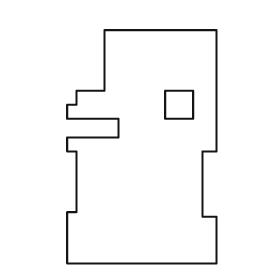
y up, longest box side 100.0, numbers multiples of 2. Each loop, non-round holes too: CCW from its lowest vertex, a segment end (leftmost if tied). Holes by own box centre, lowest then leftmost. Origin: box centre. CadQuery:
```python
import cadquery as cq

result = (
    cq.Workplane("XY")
    .moveTo(-32.0, -50.0)
    .lineTo(32.0, -50.0)
    .lineTo(32.0, -30.0)
    .lineTo(26.0, -30.0)
    .lineTo(26.0, -2.0)
    .lineTo(32.0, -2.0)
    .lineTo(32.0, 50.0)
    .lineTo(-16.0, 50.0)
    .lineTo(-16.0, 24.0)
    .lineTo(-28.0, 24.0)
    .lineTo(-28.0, 18.0)
    .lineTo(-32.0, 18.0)
    .lineTo(-32.0, 12.0)
    .lineTo(-10.0, 12.0)
    .lineTo(-10.0, 4.0)
    .lineTo(-32.0, 4.0)
    .lineTo(-32.0, -2.0)
    .lineTo(-28.0, -2.0)
    .lineTo(-28.0, -28.0)
    .lineTo(-32.0, -28.0)
    .close()
    .moveTo(10.0, 12.0)
    .lineTo(22.0, 12.0)
    .lineTo(22.0, 24.0)
    .lineTo(10.0, 24.0)
    .close()
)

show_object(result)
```